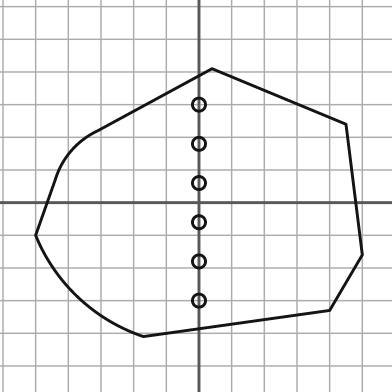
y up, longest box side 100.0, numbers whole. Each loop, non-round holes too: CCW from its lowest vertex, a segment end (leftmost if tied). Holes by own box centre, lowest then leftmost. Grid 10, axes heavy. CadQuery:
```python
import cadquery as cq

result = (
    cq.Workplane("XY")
    .moveTo(-17.0, -41.0)
    .lineTo(40.0, -33.0)
    .lineTo(50.0, -16.0)
    .lineTo(45.0, 24.0)
    .lineTo(4.0, 41.0)
    .lineTo(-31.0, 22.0)
    .threePointArc((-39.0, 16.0), (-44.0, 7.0))
    .lineTo(-50.0, -10.0)
    .threePointArc((-37.0, -29.0), (-17.0, -41.0))
    .close()
    .moveTo(0.0, -30.0)
    .circle(2.0)
    .moveTo(0.0, -18.0)
    .circle(2.0)
    .moveTo(0.0, -6.0)
    .circle(2.0)
    .moveTo(0.0, 6.0)
    .circle(2.0)
    .moveTo(0.0, 18.0)
    .circle(2.0)
    .moveTo(0.0, 30.0)
    .circle(2.0)
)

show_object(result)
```